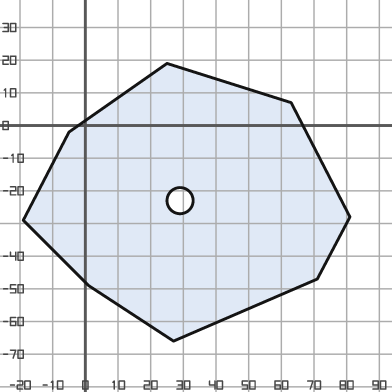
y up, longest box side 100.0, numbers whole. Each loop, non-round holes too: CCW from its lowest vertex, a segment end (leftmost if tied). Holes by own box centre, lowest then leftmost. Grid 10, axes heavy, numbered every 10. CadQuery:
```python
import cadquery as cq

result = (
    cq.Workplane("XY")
    .moveTo(27.0, -66.0)
    .lineTo(71.0, -47.0)
    .lineTo(81.0, -28.0)
    .lineTo(63.0, 7.0)
    .lineTo(25.0, 19.0)
    .lineTo(-5.0, -2.0)
    .lineTo(-19.0, -29.0)
    .lineTo(1.0, -49.0)
    .close()
    .moveTo(29.0, -23.0)
    .circle(4.0)
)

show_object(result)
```